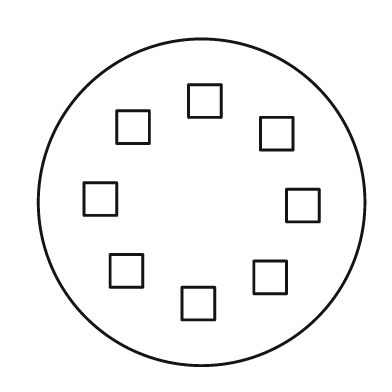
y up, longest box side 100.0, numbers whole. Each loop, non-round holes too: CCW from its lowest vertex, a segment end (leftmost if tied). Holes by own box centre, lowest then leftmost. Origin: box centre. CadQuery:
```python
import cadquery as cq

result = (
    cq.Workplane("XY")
    .moveTo(0.0, 0.0)
    .circle(50.0)
    .moveTo(-6.0, -36.0)
    .lineTo(4.0, -36.0)
    .lineTo(4.0, -26.0)
    .lineTo(-6.0, -26.0)
    .close()
    .moveTo(16.0, -28.0)
    .lineTo(26.0, -28.0)
    .lineTo(26.0, -18.0)
    .lineTo(16.0, -18.0)
    .close()
    .moveTo(-28.0, -26.0)
    .lineTo(-18.0, -26.0)
    .lineTo(-18.0, -16.0)
    .lineTo(-28.0, -16.0)
    .close()
    .moveTo(26.0, -6.0)
    .lineTo(36.0, -6.0)
    .lineTo(36.0, 4.0)
    .lineTo(26.0, 4.0)
    .close()
    .moveTo(-36.0, -4.0)
    .lineTo(-26.0, -4.0)
    .lineTo(-26.0, 6.0)
    .lineTo(-36.0, 6.0)
    .close()
    .moveTo(18.0, 16.0)
    .lineTo(28.0, 16.0)
    .lineTo(28.0, 26.0)
    .lineTo(18.0, 26.0)
    .close()
    .moveTo(-26.0, 18.0)
    .lineTo(-16.0, 18.0)
    .lineTo(-16.0, 28.0)
    .lineTo(-26.0, 28.0)
    .close()
    .moveTo(-4.0, 26.0)
    .lineTo(6.0, 26.0)
    .lineTo(6.0, 36.0)
    .lineTo(-4.0, 36.0)
    .close()
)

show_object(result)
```